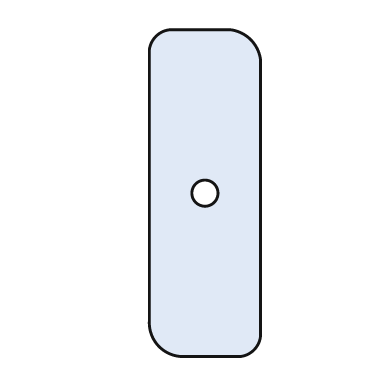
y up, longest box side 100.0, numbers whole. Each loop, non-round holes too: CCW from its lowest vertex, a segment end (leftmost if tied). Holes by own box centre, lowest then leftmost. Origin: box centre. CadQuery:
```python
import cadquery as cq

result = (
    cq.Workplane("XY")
    .moveTo(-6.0, -50.0)
    .lineTo(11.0, -50.0)
    .threePointArc((15.0, -48.0), (17.0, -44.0))
    .lineTo(17.0, 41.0)
    .threePointArc((14.0, 47.0), (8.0, 50.0))
    .lineTo(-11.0, 50.0)
    .threePointArc((-15.0, 48.0), (-17.0, 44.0))
    .lineTo(-17.0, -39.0)
    .threePointArc((-14.0, -47.0), (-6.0, -50.0))
    .close()
    .moveTo(0.0, 0.0)
    .circle(4.0)
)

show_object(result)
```